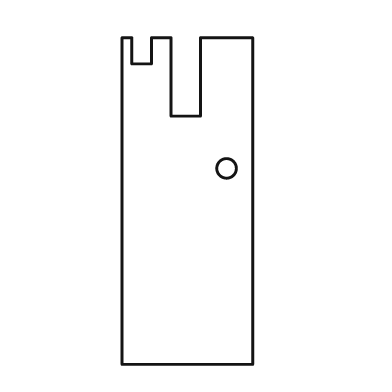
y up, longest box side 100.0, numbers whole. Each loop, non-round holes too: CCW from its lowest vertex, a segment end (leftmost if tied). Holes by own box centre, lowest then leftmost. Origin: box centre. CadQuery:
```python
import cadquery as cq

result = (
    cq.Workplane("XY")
    .moveTo(-20.0, -50.0)
    .lineTo(20.0, -50.0)
    .lineTo(20.0, 50.0)
    .lineTo(4.0, 50.0)
    .lineTo(4.0, 26.0)
    .lineTo(-5.0, 26.0)
    .lineTo(-5.0, 50.0)
    .lineTo(-11.0, 50.0)
    .lineTo(-11.0, 42.0)
    .lineTo(-17.0, 42.0)
    .lineTo(-17.0, 50.0)
    .lineTo(-20.0, 50.0)
    .close()
    .moveTo(12.0, 10.0)
    .circle(3.0)
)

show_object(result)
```